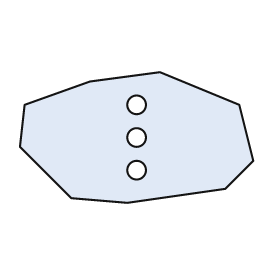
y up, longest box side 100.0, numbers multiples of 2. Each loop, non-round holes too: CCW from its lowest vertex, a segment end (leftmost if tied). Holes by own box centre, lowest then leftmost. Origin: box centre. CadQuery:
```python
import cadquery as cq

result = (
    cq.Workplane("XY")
    .moveTo(-4.0, -28.0)
    .lineTo(38.0, -22.0)
    .lineTo(50.0, -10.0)
    .lineTo(44.0, 14.0)
    .lineTo(10.0, 28.0)
    .lineTo(-20.0, 24.0)
    .lineTo(-48.0, 14.0)
    .lineTo(-50.0, -4.0)
    .lineTo(-28.0, -26.0)
    .close()
    .moveTo(0.0, -14.0)
    .circle(4.0)
    .moveTo(0.0, 0.0)
    .circle(4.0)
    .moveTo(0.0, 14.0)
    .circle(4.0)
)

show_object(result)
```